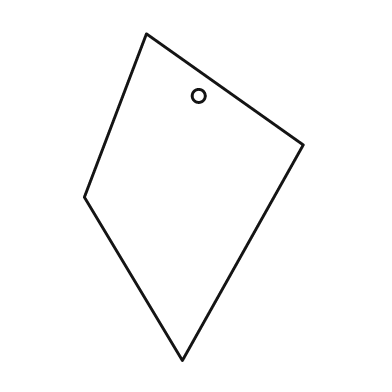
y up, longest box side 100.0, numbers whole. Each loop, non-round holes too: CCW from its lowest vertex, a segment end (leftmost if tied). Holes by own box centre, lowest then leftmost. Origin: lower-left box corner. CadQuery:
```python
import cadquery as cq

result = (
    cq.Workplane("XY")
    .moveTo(30.0, 0.0)
    .lineTo(67.0, 66.0)
    .lineTo(19.0, 100.0)
    .lineTo(0.0, 50.0)
    .close()
    .moveTo(35.0, 81.0)
    .circle(2.0)
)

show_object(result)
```